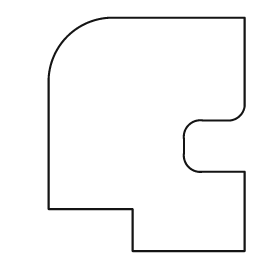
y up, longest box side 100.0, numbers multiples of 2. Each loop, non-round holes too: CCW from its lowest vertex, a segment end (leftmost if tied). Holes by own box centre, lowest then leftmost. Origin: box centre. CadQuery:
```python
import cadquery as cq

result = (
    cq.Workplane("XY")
    .moveTo(-6.0, -50.0)
    .lineTo(42.0, -50.0)
    .lineTo(42.0, -16.0)
    .lineTo(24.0, -16.0)
    .threePointArc((18.0, -14.0), (16.0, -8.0))
    .lineTo(16.0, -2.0)
    .threePointArc((18.0, 4.0), (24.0, 6.0))
    .lineTo(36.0, 6.0)
    .threePointArc((40.0, 8.0), (42.0, 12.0))
    .lineTo(42.0, 50.0)
    .lineTo(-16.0, 50.0)
    .threePointArc((-34.0, 42.0), (-42.0, 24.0))
    .lineTo(-42.0, -32.0)
    .lineTo(-6.0, -32.0)
    .close()
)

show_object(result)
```